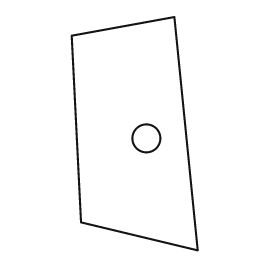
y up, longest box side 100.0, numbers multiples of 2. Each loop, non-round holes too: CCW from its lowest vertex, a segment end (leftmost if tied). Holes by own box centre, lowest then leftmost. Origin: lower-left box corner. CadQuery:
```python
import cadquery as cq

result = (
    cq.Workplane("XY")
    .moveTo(54.0, 0.0)
    .lineTo(44.0, 100.0)
    .lineTo(0.0, 92.0)
    .lineTo(4.0, 12.0)
    .close()
    .moveTo(32.0, 48.0)
    .circle(6.0)
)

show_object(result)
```